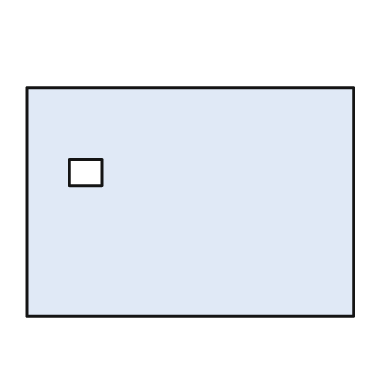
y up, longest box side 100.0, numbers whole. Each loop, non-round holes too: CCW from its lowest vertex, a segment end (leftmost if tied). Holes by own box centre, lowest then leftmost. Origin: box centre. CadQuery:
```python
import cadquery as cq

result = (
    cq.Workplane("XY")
    .moveTo(-50.0, -35.0)
    .lineTo(50.0, -35.0)
    .lineTo(50.0, 35.0)
    .lineTo(-50.0, 35.0)
    .close()
    .moveTo(-37.0, 5.0)
    .lineTo(-27.0, 5.0)
    .lineTo(-27.0, 13.0)
    .lineTo(-37.0, 13.0)
    .close()
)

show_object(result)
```